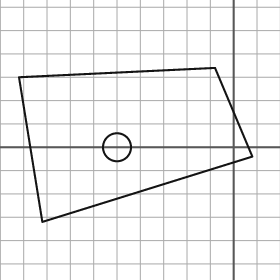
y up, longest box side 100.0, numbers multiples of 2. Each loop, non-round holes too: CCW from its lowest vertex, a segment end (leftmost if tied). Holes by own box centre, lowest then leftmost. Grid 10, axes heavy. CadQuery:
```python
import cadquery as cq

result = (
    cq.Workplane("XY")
    .moveTo(-82.0, -32.0)
    .lineTo(8.0, -4.0)
    .lineTo(-8.0, 34.0)
    .lineTo(-92.0, 30.0)
    .close()
    .moveTo(-50.0, 0.0)
    .circle(6.0)
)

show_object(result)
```